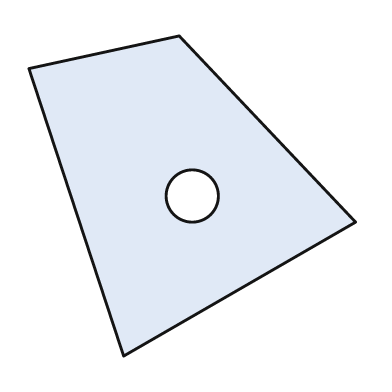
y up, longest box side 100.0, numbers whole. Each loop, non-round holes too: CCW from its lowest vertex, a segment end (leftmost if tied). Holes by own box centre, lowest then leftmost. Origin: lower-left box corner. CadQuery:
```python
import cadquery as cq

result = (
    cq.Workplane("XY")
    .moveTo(29.0, 0.0)
    .lineTo(100.0, 41.0)
    .lineTo(46.0, 98.0)
    .lineTo(0.0, 88.0)
    .close()
    .moveTo(50.0, 49.0)
    .circle(8.0)
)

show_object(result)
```